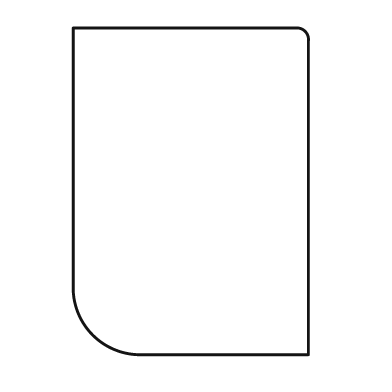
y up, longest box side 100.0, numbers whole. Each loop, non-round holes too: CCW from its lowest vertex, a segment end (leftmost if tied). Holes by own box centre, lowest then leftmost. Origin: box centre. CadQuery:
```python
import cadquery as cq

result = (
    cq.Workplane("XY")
    .moveTo(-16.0, -50.0)
    .lineTo(36.0, -50.0)
    .lineTo(36.0, 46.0)
    .threePointArc((35.0, 49.0), (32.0, 50.0))
    .lineTo(-36.0, 50.0)
    .lineTo(-36.0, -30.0)
    .threePointArc((-30.0, -44.0), (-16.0, -50.0))
    .close()
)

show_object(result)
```